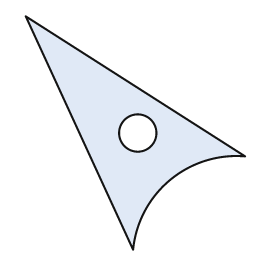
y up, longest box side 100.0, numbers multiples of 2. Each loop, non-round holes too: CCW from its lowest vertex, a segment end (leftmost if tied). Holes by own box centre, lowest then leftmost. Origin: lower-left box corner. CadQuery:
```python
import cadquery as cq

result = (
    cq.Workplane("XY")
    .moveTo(46.0, 0.0)
    .threePointArc((62.0, 30.0), (94.0, 40.0))
    .lineTo(0.0, 100.0)
    .close()
    .moveTo(48.0, 50.0)
    .circle(8.0)
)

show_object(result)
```